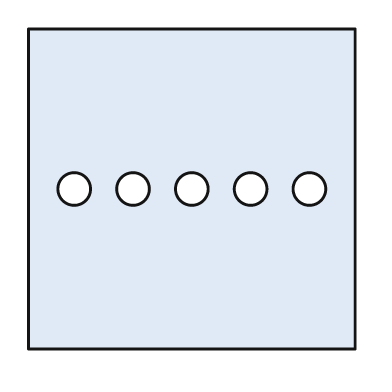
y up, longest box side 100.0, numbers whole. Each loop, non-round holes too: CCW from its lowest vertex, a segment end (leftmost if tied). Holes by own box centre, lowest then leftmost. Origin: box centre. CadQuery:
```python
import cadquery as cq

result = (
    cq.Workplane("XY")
    .moveTo(-50.0, -49.0)
    .lineTo(50.0, -49.0)
    .lineTo(50.0, 49.0)
    .lineTo(-50.0, 49.0)
    .close()
    .moveTo(-36.0, 0.0)
    .circle(5.0)
    .moveTo(-18.0, 0.0)
    .circle(5.0)
    .moveTo(0.0, 0.0)
    .circle(5.0)
    .moveTo(18.0, 0.0)
    .circle(5.0)
    .moveTo(36.0, 0.0)
    .circle(5.0)
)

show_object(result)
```